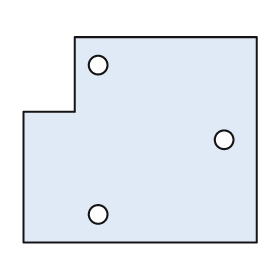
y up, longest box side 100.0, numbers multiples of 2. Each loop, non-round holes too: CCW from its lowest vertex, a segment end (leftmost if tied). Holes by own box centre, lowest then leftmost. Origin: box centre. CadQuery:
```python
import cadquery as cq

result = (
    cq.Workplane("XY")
    .moveTo(-50.0, -44.0)
    .lineTo(50.0, -44.0)
    .lineTo(50.0, 44.0)
    .lineTo(-28.0, 44.0)
    .lineTo(-28.0, 12.0)
    .lineTo(-50.0, 12.0)
    .close()
    .moveTo(-18.0, -32.0)
    .circle(4.0)
    .moveTo(36.0, 0.0)
    .circle(4.0)
    .moveTo(-18.0, 32.0)
    .circle(4.0)
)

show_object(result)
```